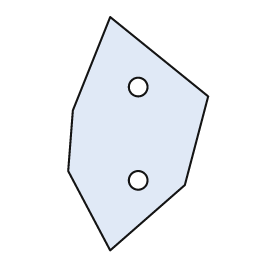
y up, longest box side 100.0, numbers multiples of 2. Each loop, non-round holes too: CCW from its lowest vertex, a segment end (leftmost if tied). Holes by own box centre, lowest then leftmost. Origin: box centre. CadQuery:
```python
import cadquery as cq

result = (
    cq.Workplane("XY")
    .moveTo(-12.0, -50.0)
    .lineTo(20.0, -22.0)
    .lineTo(30.0, 16.0)
    .lineTo(-12.0, 50.0)
    .lineTo(-28.0, 10.0)
    .lineTo(-30.0, -16.0)
    .close()
    .moveTo(0.0, -20.0)
    .circle(4.0)
    .moveTo(0.0, 20.0)
    .circle(4.0)
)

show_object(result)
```